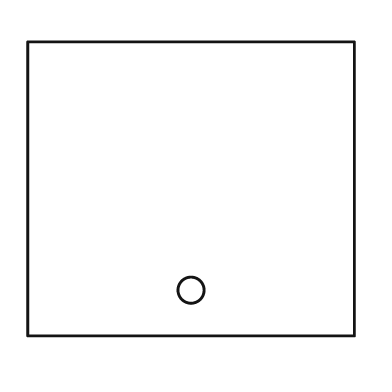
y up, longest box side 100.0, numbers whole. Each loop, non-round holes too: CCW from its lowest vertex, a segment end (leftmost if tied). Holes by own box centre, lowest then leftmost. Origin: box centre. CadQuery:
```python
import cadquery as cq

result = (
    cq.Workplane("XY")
    .moveTo(-50.0, -45.0)
    .lineTo(50.0, -45.0)
    .lineTo(50.0, 45.0)
    .lineTo(-50.0, 45.0)
    .close()
    .moveTo(0.0, -31.0)
    .circle(4.0)
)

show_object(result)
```